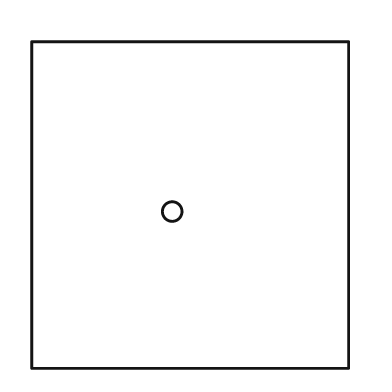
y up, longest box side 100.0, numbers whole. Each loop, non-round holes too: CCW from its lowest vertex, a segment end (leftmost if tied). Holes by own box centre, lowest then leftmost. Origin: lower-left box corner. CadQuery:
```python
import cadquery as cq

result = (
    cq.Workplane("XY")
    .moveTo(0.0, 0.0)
    .lineTo(97.0, 0.0)
    .lineTo(97.0, 100.0)
    .lineTo(0.0, 100.0)
    .close()
    .moveTo(43.0, 48.0)
    .circle(3.0)
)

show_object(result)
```